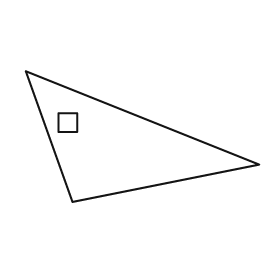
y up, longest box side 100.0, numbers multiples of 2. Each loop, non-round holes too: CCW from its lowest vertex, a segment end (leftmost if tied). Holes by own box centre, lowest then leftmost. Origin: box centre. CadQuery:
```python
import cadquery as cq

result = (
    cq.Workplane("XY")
    .moveTo(-30.0, -28.0)
    .lineTo(50.0, -12.0)
    .lineTo(-50.0, 28.0)
    .close()
    .moveTo(-36.0, 2.0)
    .lineTo(-28.0, 2.0)
    .lineTo(-28.0, 10.0)
    .lineTo(-36.0, 10.0)
    .close()
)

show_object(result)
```